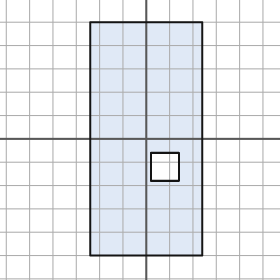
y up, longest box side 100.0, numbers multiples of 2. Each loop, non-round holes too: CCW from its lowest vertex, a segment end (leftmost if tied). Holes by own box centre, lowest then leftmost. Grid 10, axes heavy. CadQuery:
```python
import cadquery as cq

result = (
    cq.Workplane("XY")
    .moveTo(-24.0, -50.0)
    .lineTo(24.0, -50.0)
    .lineTo(24.0, 50.0)
    .lineTo(-24.0, 50.0)
    .close()
    .moveTo(2.0, -18.0)
    .lineTo(14.0, -18.0)
    .lineTo(14.0, -6.0)
    .lineTo(2.0, -6.0)
    .close()
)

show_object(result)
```